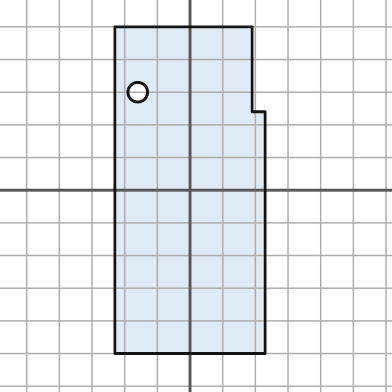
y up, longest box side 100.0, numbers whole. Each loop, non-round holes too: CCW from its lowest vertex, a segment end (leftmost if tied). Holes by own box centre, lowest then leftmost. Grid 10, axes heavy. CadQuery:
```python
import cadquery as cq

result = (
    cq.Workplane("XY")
    .moveTo(-23.0, -50.0)
    .lineTo(23.0, -50.0)
    .lineTo(23.0, 24.0)
    .lineTo(19.0, 24.0)
    .lineTo(19.0, 50.0)
    .lineTo(-23.0, 50.0)
    .close()
    .moveTo(-16.0, 30.0)
    .circle(3.0)
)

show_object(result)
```